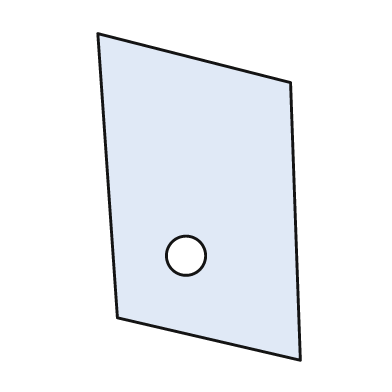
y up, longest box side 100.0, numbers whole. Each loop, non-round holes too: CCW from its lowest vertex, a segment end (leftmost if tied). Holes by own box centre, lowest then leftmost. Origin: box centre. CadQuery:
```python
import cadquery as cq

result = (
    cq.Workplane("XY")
    .moveTo(31.0, -50.0)
    .lineTo(28.0, 35.0)
    .lineTo(-31.0, 50.0)
    .lineTo(-25.0, -37.0)
    .close()
    .moveTo(-4.0, -18.0)
    .circle(6.0)
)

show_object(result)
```